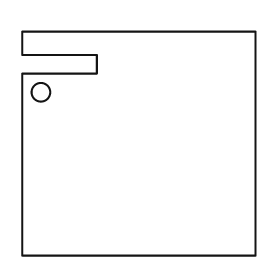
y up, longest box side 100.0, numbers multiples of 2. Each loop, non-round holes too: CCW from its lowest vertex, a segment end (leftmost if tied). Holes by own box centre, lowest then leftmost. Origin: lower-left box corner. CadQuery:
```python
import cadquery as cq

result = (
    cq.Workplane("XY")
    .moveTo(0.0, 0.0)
    .lineTo(100.0, 0.0)
    .lineTo(100.0, 96.0)
    .lineTo(0.0, 96.0)
    .lineTo(0.0, 86.0)
    .lineTo(32.0, 86.0)
    .lineTo(32.0, 78.0)
    .lineTo(0.0, 78.0)
    .close()
    .moveTo(8.0, 70.0)
    .circle(4.0)
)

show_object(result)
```